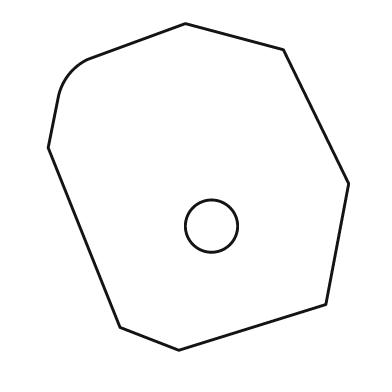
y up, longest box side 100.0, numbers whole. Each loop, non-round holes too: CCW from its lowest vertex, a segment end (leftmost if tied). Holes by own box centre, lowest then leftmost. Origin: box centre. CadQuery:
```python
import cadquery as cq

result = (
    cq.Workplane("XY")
    .moveTo(-6.0, -50.0)
    .lineTo(39.0, -36.0)
    .lineTo(46.0, 1.0)
    .lineTo(26.0, 42.0)
    .lineTo(-4.0, 50.0)
    .lineTo(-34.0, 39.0)
    .threePointArc((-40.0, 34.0), (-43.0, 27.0))
    .lineTo(-46.0, 12.0)
    .lineTo(-24.0, -43.0)
    .close()
    .moveTo(4.0, -12.0)
    .circle(8.0)
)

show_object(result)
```